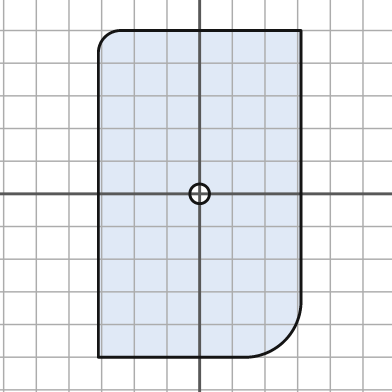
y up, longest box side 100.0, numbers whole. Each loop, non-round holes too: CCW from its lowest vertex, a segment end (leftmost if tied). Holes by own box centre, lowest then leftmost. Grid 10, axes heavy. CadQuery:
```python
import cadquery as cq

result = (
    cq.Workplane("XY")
    .moveTo(-31.0, -50.0)
    .lineTo(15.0, -50.0)
    .threePointArc((26.0, -45.0), (31.0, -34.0))
    .lineTo(31.0, 50.0)
    .lineTo(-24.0, 50.0)
    .threePointArc((-29.0, 48.0), (-31.0, 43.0))
    .close()
    .moveTo(0.0, 0.0)
    .circle(3.0)
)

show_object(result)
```